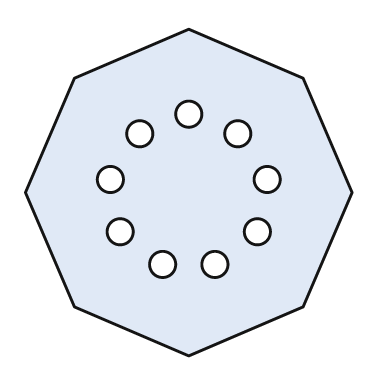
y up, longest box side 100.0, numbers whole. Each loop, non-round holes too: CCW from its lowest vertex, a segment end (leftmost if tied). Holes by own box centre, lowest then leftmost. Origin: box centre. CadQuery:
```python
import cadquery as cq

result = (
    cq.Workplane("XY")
    .moveTo(0.0, -50.0)
    .lineTo(35.0, -35.0)
    .lineTo(50.0, 0.0)
    .lineTo(35.0, 35.0)
    .lineTo(0.0, 50.0)
    .lineTo(-35.0, 35.0)
    .lineTo(-50.0, 0.0)
    .lineTo(-35.0, -35.0)
    .close()
    .moveTo(-8.0, -22.0)
    .circle(4.0)
    .moveTo(8.0, -22.0)
    .circle(4.0)
    .moveTo(-21.0, -12.0)
    .circle(4.0)
    .moveTo(21.0, -12.0)
    .circle(4.0)
    .moveTo(-24.0, 4.0)
    .circle(4.0)
    .moveTo(24.0, 4.0)
    .circle(4.0)
    .moveTo(-15.0, 18.0)
    .circle(4.0)
    .moveTo(15.0, 18.0)
    .circle(4.0)
    .moveTo(0.0, 24.0)
    .circle(4.0)
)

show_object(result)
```